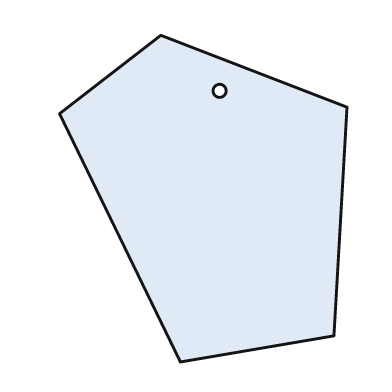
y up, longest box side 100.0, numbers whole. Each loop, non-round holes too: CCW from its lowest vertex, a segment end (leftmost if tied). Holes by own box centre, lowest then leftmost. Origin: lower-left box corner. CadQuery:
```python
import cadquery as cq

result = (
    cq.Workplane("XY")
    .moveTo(37.0, 0.0)
    .lineTo(84.0, 8.0)
    .lineTo(88.0, 78.0)
    .lineTo(31.0, 100.0)
    .lineTo(0.0, 76.0)
    .close()
    .moveTo(49.0, 83.0)
    .circle(2.0)
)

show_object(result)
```